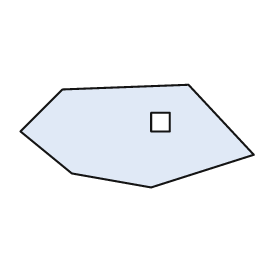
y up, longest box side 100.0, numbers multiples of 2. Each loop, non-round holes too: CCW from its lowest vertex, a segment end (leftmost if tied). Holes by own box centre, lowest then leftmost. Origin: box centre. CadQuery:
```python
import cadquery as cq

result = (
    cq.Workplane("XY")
    .moveTo(6.0, -22.0)
    .lineTo(50.0, -8.0)
    .lineTo(22.0, 22.0)
    .lineTo(-32.0, 20.0)
    .lineTo(-50.0, 2.0)
    .lineTo(-28.0, -16.0)
    .close()
    .moveTo(6.0, 2.0)
    .lineTo(14.0, 2.0)
    .lineTo(14.0, 10.0)
    .lineTo(6.0, 10.0)
    .close()
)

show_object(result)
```